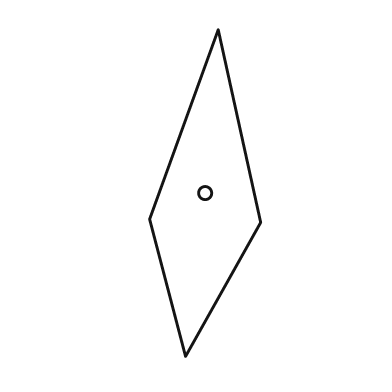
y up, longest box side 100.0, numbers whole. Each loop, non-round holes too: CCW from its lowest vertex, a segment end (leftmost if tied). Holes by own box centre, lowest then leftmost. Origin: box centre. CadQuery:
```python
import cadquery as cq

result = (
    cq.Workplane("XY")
    .moveTo(-6.0, -50.0)
    .lineTo(17.0, -9.0)
    .lineTo(4.0, 50.0)
    .lineTo(-17.0, -8.0)
    .close()
    .moveTo(0.0, 0.0)
    .circle(2.0)
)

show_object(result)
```